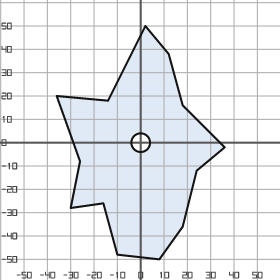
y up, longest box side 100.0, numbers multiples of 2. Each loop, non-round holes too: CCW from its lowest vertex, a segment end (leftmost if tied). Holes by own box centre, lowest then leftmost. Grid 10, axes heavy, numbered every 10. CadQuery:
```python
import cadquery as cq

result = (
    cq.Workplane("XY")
    .moveTo(8.0, -50.0)
    .lineTo(18.0, -36.0)
    .lineTo(24.0, -12.0)
    .lineTo(36.0, -2.0)
    .lineTo(18.0, 16.0)
    .lineTo(12.0, 38.0)
    .lineTo(2.0, 50.0)
    .lineTo(-14.0, 18.0)
    .lineTo(-36.0, 20.0)
    .lineTo(-26.0, -8.0)
    .lineTo(-30.0, -28.0)
    .lineTo(-16.0, -26.0)
    .lineTo(-10.0, -48.0)
    .close()
    .moveTo(0.0, 0.0)
    .circle(4.0)
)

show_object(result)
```